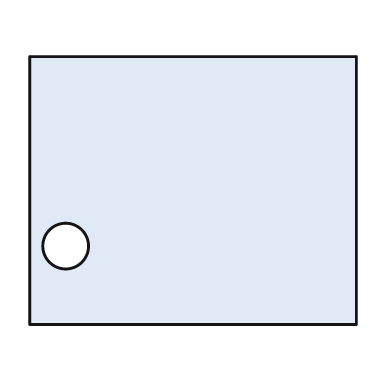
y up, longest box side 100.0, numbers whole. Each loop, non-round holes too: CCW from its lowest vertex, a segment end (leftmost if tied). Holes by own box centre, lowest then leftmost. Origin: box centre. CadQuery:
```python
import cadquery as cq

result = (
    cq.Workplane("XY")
    .moveTo(-50.0, -41.0)
    .lineTo(50.0, -41.0)
    .lineTo(50.0, 41.0)
    .lineTo(-50.0, 41.0)
    .close()
    .moveTo(-39.0, -17.0)
    .circle(7.0)
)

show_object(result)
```